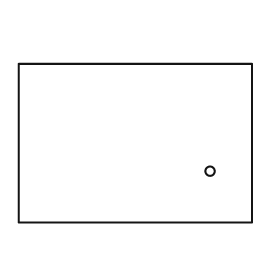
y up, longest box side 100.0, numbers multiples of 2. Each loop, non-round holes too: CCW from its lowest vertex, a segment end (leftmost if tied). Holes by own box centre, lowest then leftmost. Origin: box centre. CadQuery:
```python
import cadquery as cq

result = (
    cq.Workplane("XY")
    .moveTo(-50.0, -34.0)
    .lineTo(50.0, -34.0)
    .lineTo(50.0, 34.0)
    .lineTo(-50.0, 34.0)
    .close()
    .moveTo(32.0, -12.0)
    .circle(2.0)
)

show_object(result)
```